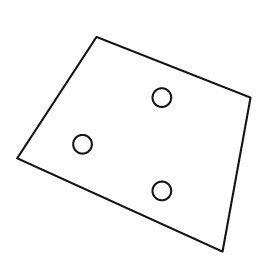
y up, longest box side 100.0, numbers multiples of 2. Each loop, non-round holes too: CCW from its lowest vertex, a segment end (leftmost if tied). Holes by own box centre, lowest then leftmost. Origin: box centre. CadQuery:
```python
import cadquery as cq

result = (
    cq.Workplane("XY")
    .moveTo(38.0, -46.0)
    .lineTo(50.0, 20.0)
    .lineTo(-16.0, 46.0)
    .lineTo(-50.0, -6.0)
    .close()
    .moveTo(12.0, -20.0)
    .circle(4.0)
    .moveTo(-22.0, 0.0)
    .circle(4.0)
    .moveTo(12.0, 20.0)
    .circle(4.0)
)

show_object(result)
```